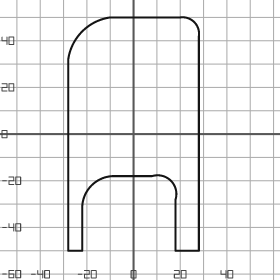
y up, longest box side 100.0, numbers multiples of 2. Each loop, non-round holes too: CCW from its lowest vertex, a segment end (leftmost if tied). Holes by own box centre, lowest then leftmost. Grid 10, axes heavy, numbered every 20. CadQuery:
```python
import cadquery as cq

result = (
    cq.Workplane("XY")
    .moveTo(-28.0, -50.0)
    .lineTo(-22.0, -50.0)
    .lineTo(-22.0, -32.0)
    .threePointArc((-18.0, -22.0), (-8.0, -18.0))
    .lineTo(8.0, -18.0)
    .threePointArc((16.0, -20.0), (18.0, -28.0))
    .lineTo(18.0, -50.0)
    .lineTo(28.0, -50.0)
    .lineTo(28.0, 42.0)
    .threePointArc((26.0, 48.0), (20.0, 50.0))
    .lineTo(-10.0, 50.0)
    .threePointArc((-22.0, 44.0), (-28.0, 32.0))
    .close()
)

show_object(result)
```